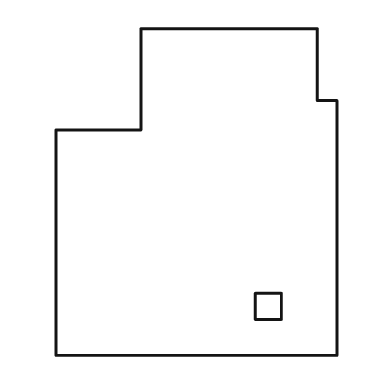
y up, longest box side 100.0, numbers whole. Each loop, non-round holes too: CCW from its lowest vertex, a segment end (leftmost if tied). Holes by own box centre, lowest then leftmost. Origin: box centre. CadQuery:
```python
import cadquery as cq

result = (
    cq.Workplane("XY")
    .moveTo(-43.0, -50.0)
    .lineTo(43.0, -50.0)
    .lineTo(43.0, 28.0)
    .lineTo(37.0, 28.0)
    .lineTo(37.0, 50.0)
    .lineTo(-17.0, 50.0)
    .lineTo(-17.0, 19.0)
    .lineTo(-43.0, 19.0)
    .close()
    .moveTo(18.0, -39.0)
    .lineTo(26.0, -39.0)
    .lineTo(26.0, -31.0)
    .lineTo(18.0, -31.0)
    .close()
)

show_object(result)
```